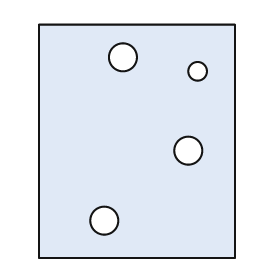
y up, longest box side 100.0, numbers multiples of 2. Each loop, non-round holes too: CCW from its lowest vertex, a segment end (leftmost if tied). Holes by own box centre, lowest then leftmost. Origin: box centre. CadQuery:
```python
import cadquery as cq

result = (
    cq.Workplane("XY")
    .moveTo(-42.0, -50.0)
    .lineTo(42.0, -50.0)
    .lineTo(42.0, 50.0)
    .lineTo(-42.0, 50.0)
    .close()
    .moveTo(-14.0, -34.0)
    .circle(6.0)
    .moveTo(22.0, -4.0)
    .circle(6.0)
    .moveTo(26.0, 30.0)
    .circle(4.0)
    .moveTo(-6.0, 36.0)
    .circle(6.0)
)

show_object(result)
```